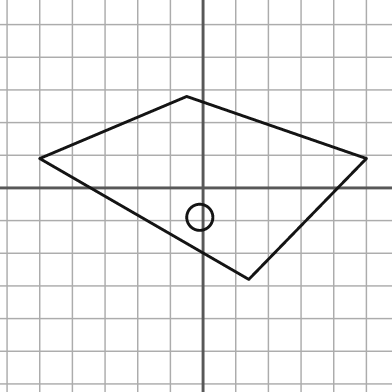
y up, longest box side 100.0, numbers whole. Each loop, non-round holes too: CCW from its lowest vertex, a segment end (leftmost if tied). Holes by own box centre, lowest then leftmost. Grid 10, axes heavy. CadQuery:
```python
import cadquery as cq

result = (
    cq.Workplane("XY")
    .moveTo(14.0, -28.0)
    .lineTo(50.0, 9.0)
    .lineTo(-5.0, 28.0)
    .lineTo(-50.0, 9.0)
    .close()
    .moveTo(-1.0, -9.0)
    .circle(4.0)
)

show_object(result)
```